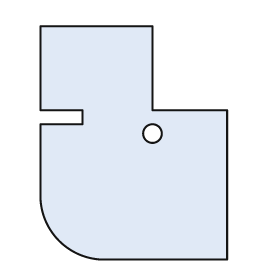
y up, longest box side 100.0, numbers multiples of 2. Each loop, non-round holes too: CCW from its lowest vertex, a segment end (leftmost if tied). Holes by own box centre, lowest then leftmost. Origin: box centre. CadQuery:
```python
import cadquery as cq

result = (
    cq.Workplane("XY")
    .moveTo(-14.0, -50.0)
    .lineTo(40.0, -50.0)
    .lineTo(40.0, 14.0)
    .lineTo(8.0, 14.0)
    .lineTo(8.0, 50.0)
    .lineTo(-40.0, 50.0)
    .lineTo(-40.0, 14.0)
    .lineTo(-22.0, 14.0)
    .lineTo(-22.0, 8.0)
    .lineTo(-40.0, 8.0)
    .lineTo(-40.0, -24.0)
    .threePointArc((-32.0, -42.0), (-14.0, -50.0))
    .close()
    .moveTo(8.0, 4.0)
    .circle(4.0)
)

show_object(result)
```